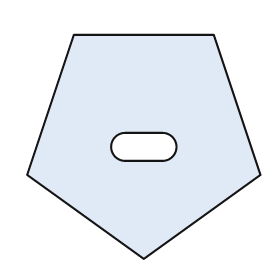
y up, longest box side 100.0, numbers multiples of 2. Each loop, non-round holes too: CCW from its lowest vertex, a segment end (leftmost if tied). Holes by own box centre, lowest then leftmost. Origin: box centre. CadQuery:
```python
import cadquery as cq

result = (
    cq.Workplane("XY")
    .moveTo(0.0, -48.0)
    .lineTo(50.0, -12.0)
    .lineTo(30.0, 48.0)
    .lineTo(-30.0, 48.0)
    .lineTo(-50.0, -12.0)
    .close()
    .moveTo(-8.0, -6.0)
    .lineTo(8.0, -6.0)
    .threePointArc((14.0, 0.0), (8.0, 6.0))
    .lineTo(-8.0, 6.0)
    .threePointArc((-14.0, 0.0), (-8.0, -6.0))
    .close()
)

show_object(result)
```